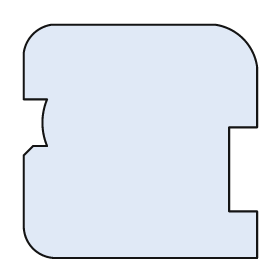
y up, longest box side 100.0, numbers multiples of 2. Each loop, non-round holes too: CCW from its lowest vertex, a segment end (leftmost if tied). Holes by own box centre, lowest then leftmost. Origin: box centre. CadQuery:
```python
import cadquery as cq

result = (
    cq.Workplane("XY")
    .moveTo(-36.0, -50.0)
    .lineTo(50.0, -50.0)
    .lineTo(50.0, -30.0)
    .lineTo(38.0, -30.0)
    .lineTo(38.0, 6.0)
    .lineTo(50.0, 6.0)
    .lineTo(50.0, 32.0)
    .threePointArc((44.0, 44.0), (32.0, 50.0))
    .lineTo(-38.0, 50.0)
    .threePointArc((-46.0, 46.0), (-50.0, 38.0))
    .lineTo(-50.0, 18.0)
    .lineTo(-40.0, 18.0)
    .threePointArc((-42.0, 8.0), (-40.0, -2.0))
    .lineTo(-46.0, -2.0)
    .lineTo(-50.0, -6.0)
    .lineTo(-50.0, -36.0)
    .threePointArc((-46.0, -46.0), (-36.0, -50.0))
    .close()
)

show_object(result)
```